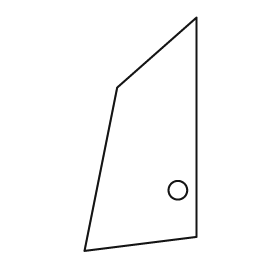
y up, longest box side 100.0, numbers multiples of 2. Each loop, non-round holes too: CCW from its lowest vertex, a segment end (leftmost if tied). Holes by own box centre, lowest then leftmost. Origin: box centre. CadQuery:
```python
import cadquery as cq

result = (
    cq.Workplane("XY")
    .moveTo(-24.0, -50.0)
    .lineTo(24.0, -44.0)
    .lineTo(24.0, 50.0)
    .lineTo(-10.0, 20.0)
    .close()
    .moveTo(16.0, -24.0)
    .circle(4.0)
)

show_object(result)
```